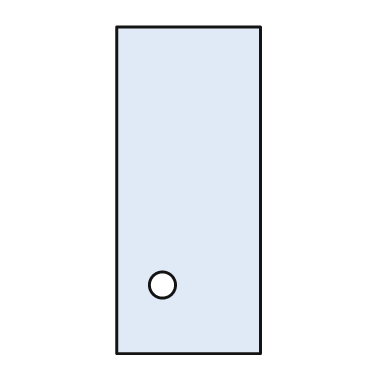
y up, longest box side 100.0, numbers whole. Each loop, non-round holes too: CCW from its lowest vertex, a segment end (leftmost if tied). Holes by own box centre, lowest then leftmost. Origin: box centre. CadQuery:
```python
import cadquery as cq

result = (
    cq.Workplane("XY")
    .moveTo(-22.0, -50.0)
    .lineTo(22.0, -50.0)
    .lineTo(22.0, 50.0)
    .lineTo(-22.0, 50.0)
    .close()
    .moveTo(-8.0, -29.0)
    .circle(4.0)
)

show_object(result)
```